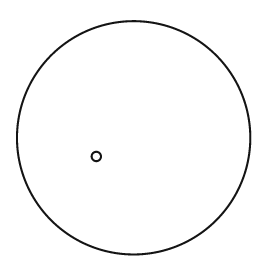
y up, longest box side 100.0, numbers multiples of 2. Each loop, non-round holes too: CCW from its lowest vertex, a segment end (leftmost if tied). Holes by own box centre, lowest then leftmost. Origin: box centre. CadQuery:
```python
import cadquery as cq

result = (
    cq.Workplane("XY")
    .moveTo(0.0, 0.0)
    .circle(50.0)
    .moveTo(-16.0, -8.0)
    .circle(2.0)
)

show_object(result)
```